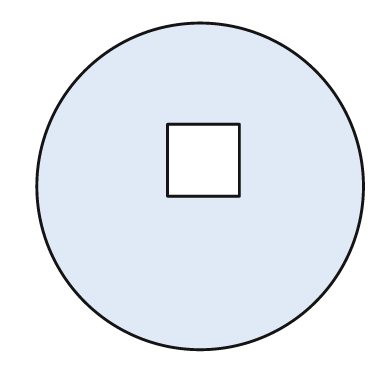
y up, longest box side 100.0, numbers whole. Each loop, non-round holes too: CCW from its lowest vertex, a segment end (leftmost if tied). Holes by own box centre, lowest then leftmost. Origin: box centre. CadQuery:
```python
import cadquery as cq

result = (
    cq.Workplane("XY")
    .moveTo(0.0, 0.0)
    .circle(50.0)
    .moveTo(-10.0, -3.0)
    .lineTo(12.0, -3.0)
    .lineTo(12.0, 19.0)
    .lineTo(-10.0, 19.0)
    .close()
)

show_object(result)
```